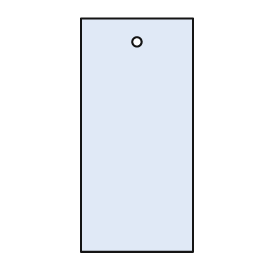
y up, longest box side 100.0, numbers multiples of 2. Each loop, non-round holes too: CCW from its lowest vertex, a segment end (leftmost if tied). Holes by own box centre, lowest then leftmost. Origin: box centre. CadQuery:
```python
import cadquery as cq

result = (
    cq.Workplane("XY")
    .moveTo(-24.0, -50.0)
    .lineTo(24.0, -50.0)
    .lineTo(24.0, 50.0)
    .lineTo(-24.0, 50.0)
    .close()
    .moveTo(0.0, 40.0)
    .circle(2.0)
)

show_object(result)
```